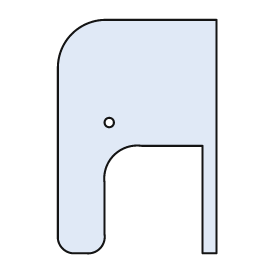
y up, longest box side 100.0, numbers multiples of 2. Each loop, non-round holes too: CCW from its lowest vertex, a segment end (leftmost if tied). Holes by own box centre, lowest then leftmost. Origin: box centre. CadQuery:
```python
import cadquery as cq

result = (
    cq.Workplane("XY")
    .moveTo(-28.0, -50.0)
    .lineTo(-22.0, -50.0)
    .threePointArc((-16.0, -48.0), (-14.0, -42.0))
    .lineTo(-14.0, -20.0)
    .threePointArc((-10.0, -8.0), (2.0, -4.0))
    .lineTo(28.0, -4.0)
    .lineTo(28.0, -50.0)
    .lineTo(34.0, -50.0)
    .lineTo(34.0, 50.0)
    .lineTo(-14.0, 50.0)
    .threePointArc((-28.0, 44.0), (-34.0, 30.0))
    .lineTo(-34.0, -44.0)
    .threePointArc((-32.0, -48.0), (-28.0, -50.0))
    .close()
    .moveTo(-12.0, 6.0)
    .circle(2.0)
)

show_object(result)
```